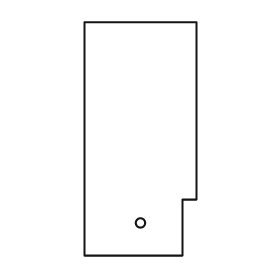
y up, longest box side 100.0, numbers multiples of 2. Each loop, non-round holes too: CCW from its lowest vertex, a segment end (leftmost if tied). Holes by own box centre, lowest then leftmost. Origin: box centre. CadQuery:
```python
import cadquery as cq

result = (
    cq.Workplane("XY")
    .moveTo(-24.0, -50.0)
    .lineTo(18.0, -50.0)
    .lineTo(18.0, -26.0)
    .lineTo(24.0, -26.0)
    .lineTo(24.0, 50.0)
    .lineTo(-24.0, 50.0)
    .close()
    .moveTo(0.0, -36.0)
    .circle(2.0)
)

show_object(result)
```